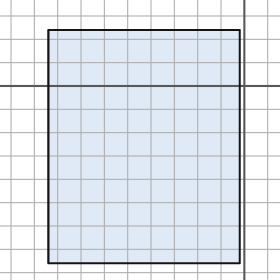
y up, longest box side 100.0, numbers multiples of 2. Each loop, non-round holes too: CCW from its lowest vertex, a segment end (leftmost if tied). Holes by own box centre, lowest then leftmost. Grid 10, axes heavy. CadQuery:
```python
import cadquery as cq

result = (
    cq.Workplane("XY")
    .moveTo(-84.0, -76.0)
    .lineTo(-2.0, -76.0)
    .lineTo(-2.0, 24.0)
    .lineTo(-84.0, 24.0)
    .close()
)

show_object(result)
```